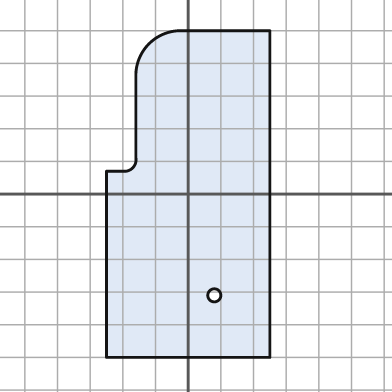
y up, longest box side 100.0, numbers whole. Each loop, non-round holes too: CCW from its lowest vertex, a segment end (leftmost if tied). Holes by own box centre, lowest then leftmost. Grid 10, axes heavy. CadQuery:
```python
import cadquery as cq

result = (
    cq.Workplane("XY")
    .moveTo(-25.0, -50.0)
    .lineTo(25.0, -50.0)
    .lineTo(25.0, 50.0)
    .lineTo(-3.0, 50.0)
    .threePointArc((-12.0, 46.0), (-16.0, 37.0))
    .lineTo(-16.0, 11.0)
    .threePointArc((-17.0, 8.0), (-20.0, 7.0))
    .lineTo(-25.0, 7.0)
    .close()
    .moveTo(8.0, -31.0)
    .circle(2.0)
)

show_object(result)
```